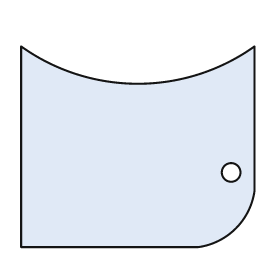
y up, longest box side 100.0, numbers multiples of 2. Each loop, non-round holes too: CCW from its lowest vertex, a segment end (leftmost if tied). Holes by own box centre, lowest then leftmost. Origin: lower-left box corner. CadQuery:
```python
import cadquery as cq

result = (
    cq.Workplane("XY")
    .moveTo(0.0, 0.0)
    .lineTo(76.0, 0.0)
    .threePointArc((92.0, 8.0), (100.0, 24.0))
    .lineTo(100.0, 86.0)
    .threePointArc((50.0, 70.0), (0.0, 86.0))
    .close()
    .moveTo(90.0, 32.0)
    .circle(4.0)
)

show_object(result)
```